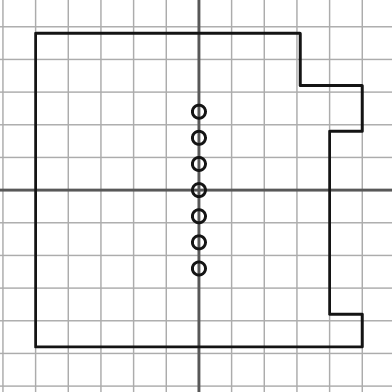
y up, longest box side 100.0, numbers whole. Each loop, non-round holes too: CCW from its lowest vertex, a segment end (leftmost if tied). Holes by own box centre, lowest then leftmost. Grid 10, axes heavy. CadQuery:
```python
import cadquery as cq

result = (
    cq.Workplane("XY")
    .moveTo(-50.0, -48.0)
    .lineTo(50.0, -48.0)
    .lineTo(50.0, -38.0)
    .lineTo(40.0, -38.0)
    .lineTo(40.0, 18.0)
    .lineTo(50.0, 18.0)
    .lineTo(50.0, 32.0)
    .lineTo(31.0, 32.0)
    .lineTo(31.0, 48.0)
    .lineTo(-50.0, 48.0)
    .close()
    .moveTo(0.0, -24.0)
    .circle(2.0)
    .moveTo(0.0, -16.0)
    .circle(2.0)
    .moveTo(0.0, -8.0)
    .circle(2.0)
    .moveTo(0.0, 0.0)
    .circle(2.0)
    .moveTo(0.0, 8.0)
    .circle(2.0)
    .moveTo(0.0, 16.0)
    .circle(2.0)
    .moveTo(0.0, 24.0)
    .circle(2.0)
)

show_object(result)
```